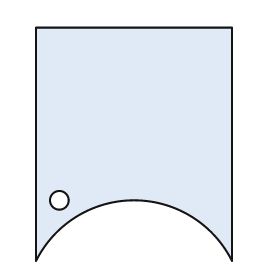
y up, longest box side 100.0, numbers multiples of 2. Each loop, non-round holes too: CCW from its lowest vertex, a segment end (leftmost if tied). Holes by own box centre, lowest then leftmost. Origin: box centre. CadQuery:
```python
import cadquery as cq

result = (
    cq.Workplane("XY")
    .moveTo(-42.0, -50.0)
    .threePointArc((0.0, -24.0), (42.0, -50.0))
    .lineTo(42.0, 50.0)
    .lineTo(-42.0, 50.0)
    .close()
    .moveTo(-32.0, -24.0)
    .circle(4.0)
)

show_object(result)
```